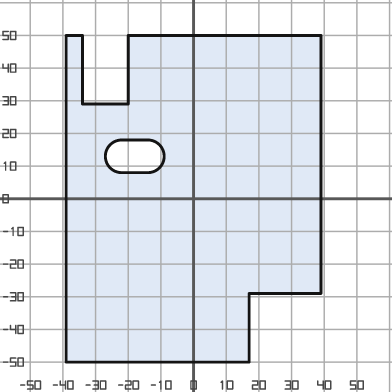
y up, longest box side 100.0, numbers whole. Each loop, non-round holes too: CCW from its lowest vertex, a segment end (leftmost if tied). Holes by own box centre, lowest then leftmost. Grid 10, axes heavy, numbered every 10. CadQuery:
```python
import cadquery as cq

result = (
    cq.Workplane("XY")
    .moveTo(-39.0, -50.0)
    .lineTo(17.0, -50.0)
    .lineTo(17.0, -29.0)
    .lineTo(39.0, -29.0)
    .lineTo(39.0, 50.0)
    .lineTo(-20.0, 50.0)
    .lineTo(-20.0, 29.0)
    .lineTo(-34.0, 29.0)
    .lineTo(-34.0, 50.0)
    .lineTo(-39.0, 50.0)
    .close()
    .moveTo(-22.0, 8.0)
    .lineTo(-14.0, 8.0)
    .threePointArc((-9.0, 13.0), (-14.0, 18.0))
    .lineTo(-22.0, 18.0)
    .threePointArc((-27.0, 13.0), (-22.0, 8.0))
    .close()
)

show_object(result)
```